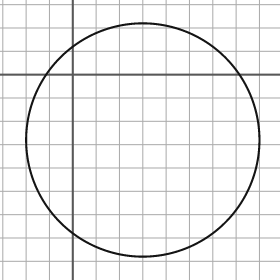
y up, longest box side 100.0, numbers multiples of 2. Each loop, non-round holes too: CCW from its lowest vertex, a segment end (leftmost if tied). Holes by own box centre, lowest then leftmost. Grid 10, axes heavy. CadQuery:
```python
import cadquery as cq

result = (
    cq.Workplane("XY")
    .moveTo(30.0, -28.0)
    .circle(50.0)
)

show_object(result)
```